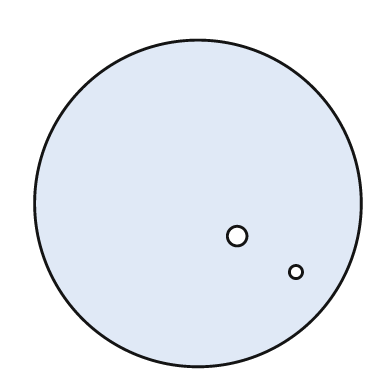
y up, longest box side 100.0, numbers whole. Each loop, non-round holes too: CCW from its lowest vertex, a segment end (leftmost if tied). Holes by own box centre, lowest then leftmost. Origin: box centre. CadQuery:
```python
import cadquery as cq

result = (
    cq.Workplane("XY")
    .moveTo(0.0, 0.0)
    .circle(50.0)
    .moveTo(30.0, -21.0)
    .circle(2.0)
    .moveTo(12.0, -10.0)
    .circle(3.0)
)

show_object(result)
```